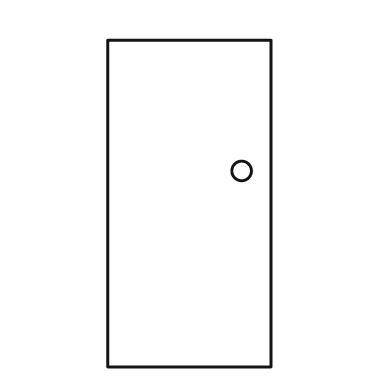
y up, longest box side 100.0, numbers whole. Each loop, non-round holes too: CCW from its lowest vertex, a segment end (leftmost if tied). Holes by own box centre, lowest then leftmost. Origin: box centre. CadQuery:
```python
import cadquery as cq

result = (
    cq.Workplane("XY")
    .moveTo(-25.0, -50.0)
    .lineTo(25.0, -50.0)
    .lineTo(25.0, 50.0)
    .lineTo(-25.0, 50.0)
    .close()
    .moveTo(16.0, 10.0)
    .circle(3.0)
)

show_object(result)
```